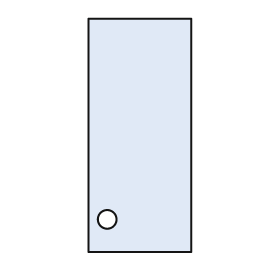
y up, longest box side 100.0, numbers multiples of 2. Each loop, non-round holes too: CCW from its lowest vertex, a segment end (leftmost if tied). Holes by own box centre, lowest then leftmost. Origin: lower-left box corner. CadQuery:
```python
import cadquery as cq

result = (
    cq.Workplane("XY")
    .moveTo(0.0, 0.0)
    .lineTo(44.0, 0.0)
    .lineTo(44.0, 100.0)
    .lineTo(0.0, 100.0)
    .close()
    .moveTo(8.0, 14.0)
    .circle(4.0)
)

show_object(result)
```